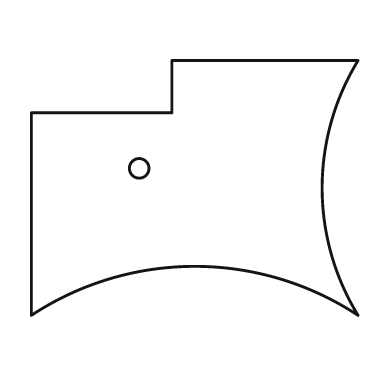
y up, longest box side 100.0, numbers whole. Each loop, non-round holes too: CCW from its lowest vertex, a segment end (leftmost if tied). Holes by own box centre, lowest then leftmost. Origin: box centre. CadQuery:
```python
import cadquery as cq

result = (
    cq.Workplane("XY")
    .moveTo(-50.0, -39.0)
    .threePointArc((0.0, -24.0), (50.0, -39.0))
    .threePointArc((39.0, 0.0), (50.0, 39.0))
    .lineTo(-7.0, 39.0)
    .lineTo(-7.0, 23.0)
    .lineTo(-50.0, 23.0)
    .close()
    .moveTo(-17.0, 6.0)
    .circle(3.0)
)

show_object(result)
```